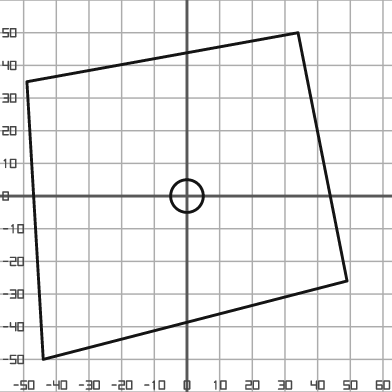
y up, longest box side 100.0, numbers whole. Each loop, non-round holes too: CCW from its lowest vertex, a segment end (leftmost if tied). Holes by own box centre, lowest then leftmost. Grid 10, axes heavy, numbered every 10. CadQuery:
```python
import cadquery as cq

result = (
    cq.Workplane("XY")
    .moveTo(-44.0, -50.0)
    .lineTo(49.0, -26.0)
    .lineTo(34.0, 50.0)
    .lineTo(-49.0, 35.0)
    .close()
    .moveTo(0.0, 0.0)
    .circle(5.0)
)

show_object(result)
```